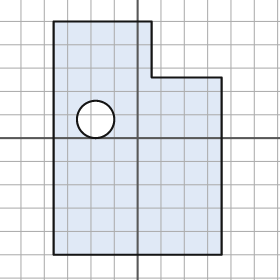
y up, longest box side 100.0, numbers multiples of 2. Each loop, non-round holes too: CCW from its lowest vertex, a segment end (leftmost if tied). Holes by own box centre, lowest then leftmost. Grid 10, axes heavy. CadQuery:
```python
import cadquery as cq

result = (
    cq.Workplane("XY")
    .moveTo(-36.0, -50.0)
    .lineTo(36.0, -50.0)
    .lineTo(36.0, 26.0)
    .lineTo(6.0, 26.0)
    .lineTo(6.0, 50.0)
    .lineTo(-36.0, 50.0)
    .close()
    .moveTo(-18.0, 8.0)
    .circle(8.0)
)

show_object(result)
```